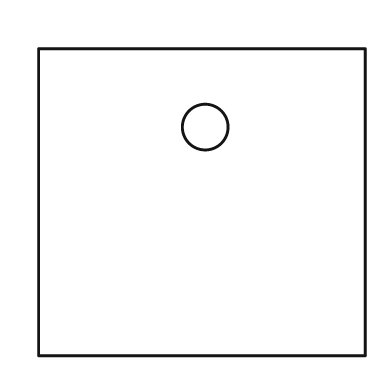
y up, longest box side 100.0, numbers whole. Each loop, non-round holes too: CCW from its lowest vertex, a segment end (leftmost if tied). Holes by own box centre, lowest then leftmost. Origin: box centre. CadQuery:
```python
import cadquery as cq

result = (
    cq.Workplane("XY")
    .moveTo(-50.0, -47.0)
    .lineTo(50.0, -47.0)
    .lineTo(50.0, 47.0)
    .lineTo(-50.0, 47.0)
    .close()
    .moveTo(1.0, 23.0)
    .circle(7.0)
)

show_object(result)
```